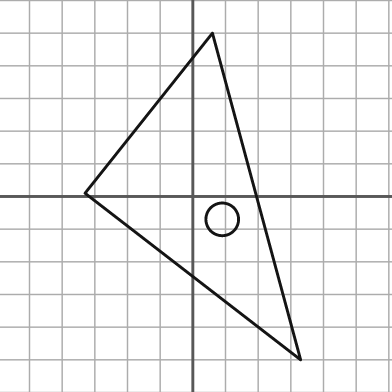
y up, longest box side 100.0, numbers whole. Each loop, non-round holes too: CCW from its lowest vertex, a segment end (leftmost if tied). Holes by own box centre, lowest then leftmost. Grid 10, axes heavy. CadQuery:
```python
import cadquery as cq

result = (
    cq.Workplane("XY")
    .moveTo(33.0, -50.0)
    .lineTo(6.0, 50.0)
    .lineTo(-33.0, 1.0)
    .close()
    .moveTo(9.0, -7.0)
    .circle(5.0)
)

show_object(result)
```